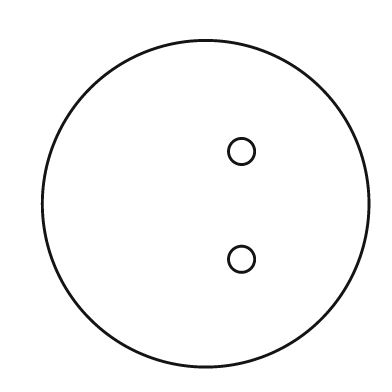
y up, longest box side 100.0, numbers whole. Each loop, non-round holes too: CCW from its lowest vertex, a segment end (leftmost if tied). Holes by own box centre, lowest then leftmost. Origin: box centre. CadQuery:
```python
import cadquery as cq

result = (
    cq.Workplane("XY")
    .moveTo(0.0, 0.0)
    .circle(50.0)
    .moveTo(11.0, -17.0)
    .circle(4.0)
    .moveTo(11.0, 16.0)
    .circle(4.0)
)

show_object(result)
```